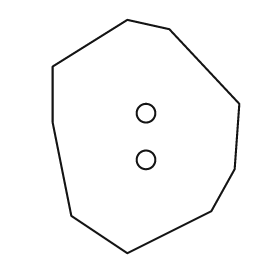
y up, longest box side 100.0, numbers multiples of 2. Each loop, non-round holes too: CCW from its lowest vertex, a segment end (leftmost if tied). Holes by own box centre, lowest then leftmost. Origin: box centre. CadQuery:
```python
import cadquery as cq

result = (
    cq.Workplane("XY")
    .moveTo(-8.0, -50.0)
    .lineTo(28.0, -32.0)
    .lineTo(38.0, -14.0)
    .lineTo(40.0, 14.0)
    .lineTo(10.0, 46.0)
    .lineTo(-8.0, 50.0)
    .lineTo(-40.0, 30.0)
    .lineTo(-40.0, 6.0)
    .lineTo(-32.0, -34.0)
    .close()
    .moveTo(0.0, -10.0)
    .circle(4.0)
    .moveTo(0.0, 10.0)
    .circle(4.0)
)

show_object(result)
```